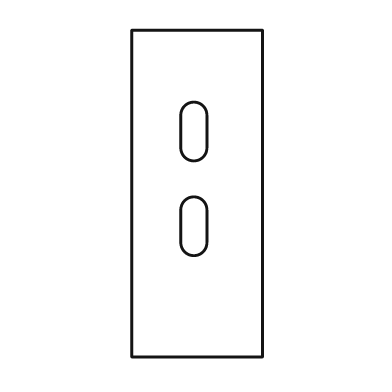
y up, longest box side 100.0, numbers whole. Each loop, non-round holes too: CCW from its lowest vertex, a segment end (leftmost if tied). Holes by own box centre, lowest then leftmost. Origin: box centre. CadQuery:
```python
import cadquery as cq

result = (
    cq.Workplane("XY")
    .moveTo(-20.0, -50.0)
    .lineTo(20.0, -50.0)
    .lineTo(20.0, 50.0)
    .lineTo(-20.0, 50.0)
    .close()
    .moveTo(-5.0, -15.0)
    .threePointArc((-1.0, -19.0), (3.0, -15.0))
    .lineTo(3.0, -5.0)
    .threePointArc((-1.0, -1.0), (-5.0, -5.0))
    .close()
    .moveTo(-5.0, 14.0)
    .threePointArc((-1.0, 10.0), (3.0, 14.0))
    .lineTo(3.0, 24.0)
    .threePointArc((-1.0, 28.0), (-5.0, 24.0))
    .close()
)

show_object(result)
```